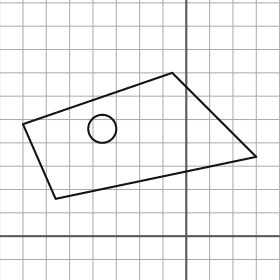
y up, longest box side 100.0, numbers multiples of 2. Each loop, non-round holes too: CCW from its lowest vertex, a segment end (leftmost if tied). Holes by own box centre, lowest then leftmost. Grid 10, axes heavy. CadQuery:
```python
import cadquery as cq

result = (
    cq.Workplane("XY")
    .moveTo(-56.0, 16.0)
    .lineTo(30.0, 34.0)
    .lineTo(-6.0, 70.0)
    .lineTo(-70.0, 48.0)
    .close()
    .moveTo(-36.0, 46.0)
    .circle(6.0)
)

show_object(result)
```